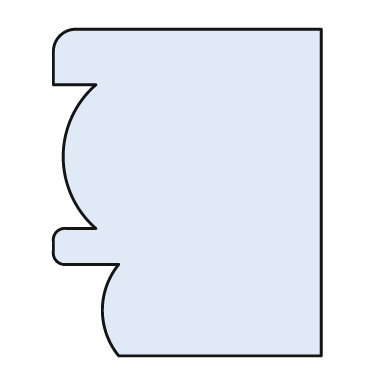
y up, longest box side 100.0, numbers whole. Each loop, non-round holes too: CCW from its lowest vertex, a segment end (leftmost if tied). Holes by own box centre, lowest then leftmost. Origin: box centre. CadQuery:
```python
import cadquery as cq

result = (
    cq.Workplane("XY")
    .moveTo(-21.0, -50.0)
    .lineTo(41.0, -50.0)
    .lineTo(41.0, 50.0)
    .lineTo(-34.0, 50.0)
    .threePointArc((-39.0, 48.0), (-41.0, 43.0))
    .lineTo(-41.0, 33.0)
    .lineTo(-28.0, 33.0)
    .threePointArc((-38.0, 11.0), (-28.0, -11.0))
    .lineTo(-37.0, -11.0)
    .threePointArc((-40.0, -12.0), (-41.0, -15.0))
    .lineTo(-41.0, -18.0)
    .threePointArc((-40.0, -21.0), (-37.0, -22.0))
    .lineTo(-21.0, -22.0)
    .threePointArc((-26.0, -36.0), (-21.0, -50.0))
    .close()
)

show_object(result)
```